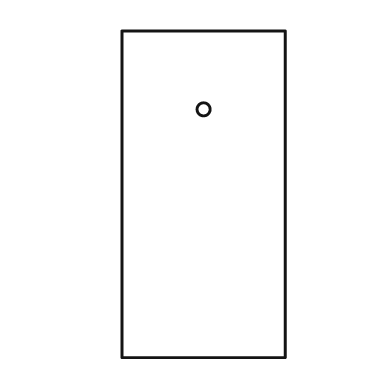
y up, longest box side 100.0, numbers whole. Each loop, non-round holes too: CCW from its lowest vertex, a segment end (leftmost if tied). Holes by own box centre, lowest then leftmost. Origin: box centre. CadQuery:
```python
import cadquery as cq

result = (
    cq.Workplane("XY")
    .moveTo(-25.0, -50.0)
    .lineTo(25.0, -50.0)
    .lineTo(25.0, 50.0)
    .lineTo(-25.0, 50.0)
    .close()
    .moveTo(0.0, 26.0)
    .circle(2.0)
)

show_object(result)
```